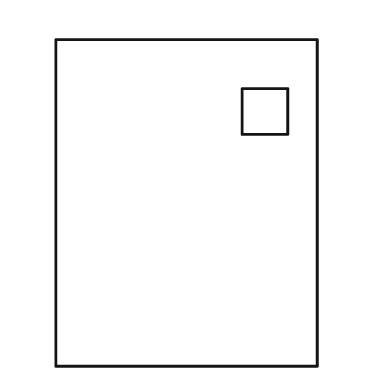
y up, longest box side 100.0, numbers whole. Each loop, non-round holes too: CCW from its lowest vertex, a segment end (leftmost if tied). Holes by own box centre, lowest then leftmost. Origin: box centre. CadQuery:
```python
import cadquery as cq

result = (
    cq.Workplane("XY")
    .moveTo(-40.0, -50.0)
    .lineTo(40.0, -50.0)
    .lineTo(40.0, 50.0)
    .lineTo(-40.0, 50.0)
    .close()
    .moveTo(17.0, 21.0)
    .lineTo(31.0, 21.0)
    .lineTo(31.0, 35.0)
    .lineTo(17.0, 35.0)
    .close()
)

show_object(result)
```